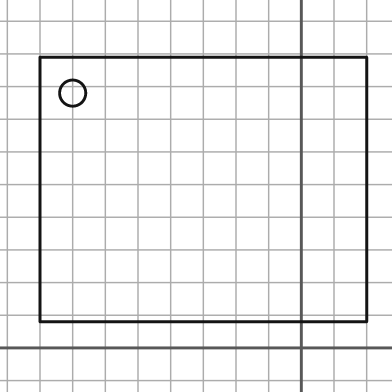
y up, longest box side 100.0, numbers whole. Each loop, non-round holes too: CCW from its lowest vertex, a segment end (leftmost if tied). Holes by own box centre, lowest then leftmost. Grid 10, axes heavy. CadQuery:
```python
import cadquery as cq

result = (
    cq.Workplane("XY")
    .moveTo(-80.0, 8.0)
    .lineTo(20.0, 8.0)
    .lineTo(20.0, 89.0)
    .lineTo(-80.0, 89.0)
    .close()
    .moveTo(-70.0, 78.0)
    .circle(4.0)
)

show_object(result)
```